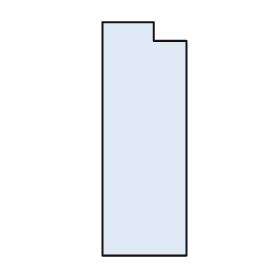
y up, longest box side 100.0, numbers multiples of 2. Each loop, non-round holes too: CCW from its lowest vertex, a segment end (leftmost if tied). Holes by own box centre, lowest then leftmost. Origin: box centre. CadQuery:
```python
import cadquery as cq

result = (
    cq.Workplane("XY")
    .moveTo(-18.0, -50.0)
    .lineTo(18.0, -50.0)
    .lineTo(18.0, 42.0)
    .lineTo(4.0, 42.0)
    .lineTo(4.0, 50.0)
    .lineTo(-18.0, 50.0)
    .close()
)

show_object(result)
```